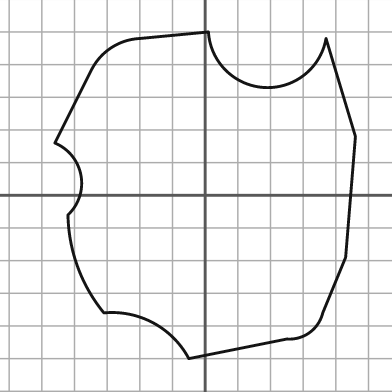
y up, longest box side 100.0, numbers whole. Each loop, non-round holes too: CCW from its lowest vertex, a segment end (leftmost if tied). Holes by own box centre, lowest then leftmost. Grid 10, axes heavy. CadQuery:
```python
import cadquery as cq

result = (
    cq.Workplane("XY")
    .moveTo(-5.0, -50.0)
    .lineTo(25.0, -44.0)
    .threePointArc((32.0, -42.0), (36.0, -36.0))
    .lineTo(43.0, -19.0)
    .lineTo(46.0, 18.0)
    .lineTo(37.0, 48.0)
    .threePointArc((18.0, 33.0), (1.0, 50.0))
    .lineTo(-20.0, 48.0)
    .threePointArc((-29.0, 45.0), (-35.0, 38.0))
    .lineTo(-46.0, 16.0)
    .threePointArc((-38.0, 6.0), (-42.0, -6.0))
    .threePointArc((-39.0, -22.0), (-31.0, -36.0))
    .threePointArc((-16.0, -39.0), (-5.0, -50.0))
    .close()
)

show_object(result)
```